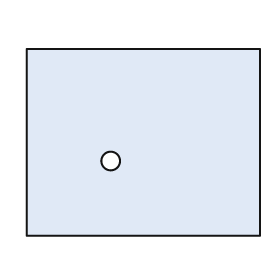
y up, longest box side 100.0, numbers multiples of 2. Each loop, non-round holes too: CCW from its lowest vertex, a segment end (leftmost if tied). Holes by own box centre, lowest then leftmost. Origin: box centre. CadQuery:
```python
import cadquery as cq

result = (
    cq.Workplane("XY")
    .moveTo(-50.0, -40.0)
    .lineTo(50.0, -40.0)
    .lineTo(50.0, 40.0)
    .lineTo(-50.0, 40.0)
    .close()
    .moveTo(-14.0, -8.0)
    .circle(4.0)
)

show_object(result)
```